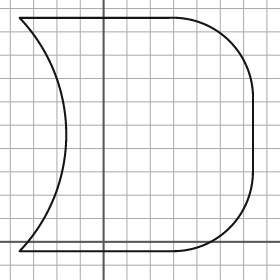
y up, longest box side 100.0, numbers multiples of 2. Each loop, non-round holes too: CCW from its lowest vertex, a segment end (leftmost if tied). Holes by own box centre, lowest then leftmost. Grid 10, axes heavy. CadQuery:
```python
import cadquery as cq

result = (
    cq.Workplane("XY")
    .moveTo(-36.0, -4.0)
    .lineTo(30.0, -4.0)
    .threePointArc((54.0, 6.0), (64.0, 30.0))
    .lineTo(64.0, 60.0)
    .threePointArc((54.0, 86.0), (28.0, 96.0))
    .lineTo(-36.0, 96.0)
    .threePointArc((-16.0, 46.0), (-36.0, -4.0))
    .close()
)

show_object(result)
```